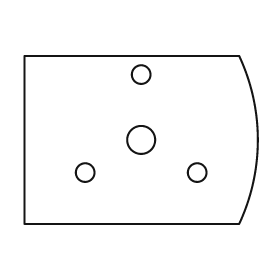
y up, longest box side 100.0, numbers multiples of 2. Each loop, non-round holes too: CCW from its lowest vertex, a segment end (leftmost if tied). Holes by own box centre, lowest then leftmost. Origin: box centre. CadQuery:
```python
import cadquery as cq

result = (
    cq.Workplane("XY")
    .moveTo(-50.0, -36.0)
    .lineTo(42.0, -36.0)
    .threePointArc((50.0, 0.0), (42.0, 36.0))
    .lineTo(-50.0, 36.0)
    .close()
    .moveTo(-24.0, -14.0)
    .circle(4.0)
    .moveTo(24.0, -14.0)
    .circle(4.0)
    .moveTo(0.0, 0.0)
    .circle(6.0)
    .moveTo(0.0, 28.0)
    .circle(4.0)
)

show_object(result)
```